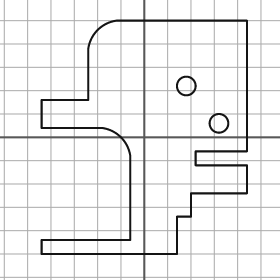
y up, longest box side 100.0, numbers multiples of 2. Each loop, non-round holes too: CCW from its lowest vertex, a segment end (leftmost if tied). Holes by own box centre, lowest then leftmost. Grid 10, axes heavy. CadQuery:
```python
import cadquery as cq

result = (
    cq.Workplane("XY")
    .moveTo(-44.0, -50.0)
    .lineTo(14.0, -50.0)
    .lineTo(14.0, -34.0)
    .lineTo(20.0, -34.0)
    .lineTo(20.0, -24.0)
    .lineTo(44.0, -24.0)
    .lineTo(44.0, -12.0)
    .lineTo(22.0, -12.0)
    .lineTo(22.0, -6.0)
    .lineTo(44.0, -6.0)
    .lineTo(44.0, 50.0)
    .lineTo(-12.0, 50.0)
    .threePointArc((-20.0, 46.0), (-24.0, 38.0))
    .lineTo(-24.0, 16.0)
    .lineTo(-44.0, 16.0)
    .lineTo(-44.0, 4.0)
    .lineTo(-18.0, 4.0)
    .threePointArc((-10.0, 0.0), (-6.0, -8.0))
    .lineTo(-6.0, -44.0)
    .lineTo(-44.0, -44.0)
    .close()
    .moveTo(32.0, 6.0)
    .circle(4.0)
    .moveTo(18.0, 22.0)
    .circle(4.0)
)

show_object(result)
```